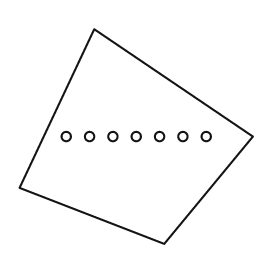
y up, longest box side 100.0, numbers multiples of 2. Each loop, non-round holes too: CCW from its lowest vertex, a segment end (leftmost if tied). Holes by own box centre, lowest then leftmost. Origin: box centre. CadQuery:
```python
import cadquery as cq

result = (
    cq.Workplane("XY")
    .moveTo(12.0, -46.0)
    .lineTo(50.0, 0.0)
    .lineTo(-18.0, 46.0)
    .lineTo(-50.0, -22.0)
    .close()
    .moveTo(-30.0, 0.0)
    .circle(2.0)
    .moveTo(-20.0, 0.0)
    .circle(2.0)
    .moveTo(-10.0, 0.0)
    .circle(2.0)
    .moveTo(0.0, 0.0)
    .circle(2.0)
    .moveTo(10.0, 0.0)
    .circle(2.0)
    .moveTo(20.0, 0.0)
    .circle(2.0)
    .moveTo(30.0, 0.0)
    .circle(2.0)
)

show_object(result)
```